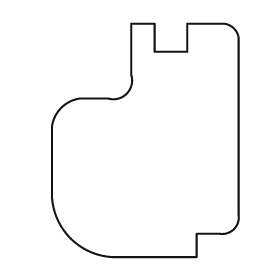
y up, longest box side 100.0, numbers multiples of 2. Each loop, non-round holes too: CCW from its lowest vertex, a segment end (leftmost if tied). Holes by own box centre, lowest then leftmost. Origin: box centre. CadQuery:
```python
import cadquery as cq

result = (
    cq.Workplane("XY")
    .moveTo(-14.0, -50.0)
    .lineTo(22.0, -50.0)
    .lineTo(22.0, -40.0)
    .lineTo(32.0, -40.0)
    .threePointArc((38.0, -38.0), (40.0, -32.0))
    .lineTo(40.0, 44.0)
    .threePointArc((38.0, 48.0), (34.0, 50.0))
    .lineTo(18.0, 50.0)
    .lineTo(18.0, 38.0)
    .lineTo(4.0, 38.0)
    .lineTo(4.0, 50.0)
    .lineTo(-6.0, 50.0)
    .lineTo(-6.0, 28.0)
    .threePointArc((-8.0, 20.0), (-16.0, 18.0))
    .lineTo(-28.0, 18.0)
    .threePointArc((-36.0, 14.0), (-40.0, 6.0))
    .lineTo(-40.0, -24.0)
    .threePointArc((-32.0, -42.0), (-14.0, -50.0))
    .close()
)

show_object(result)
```